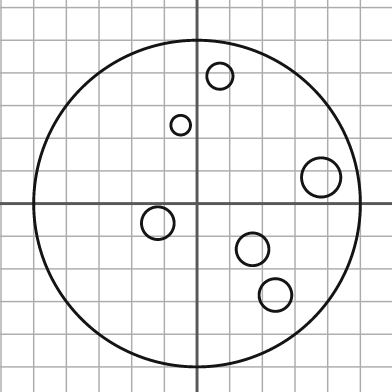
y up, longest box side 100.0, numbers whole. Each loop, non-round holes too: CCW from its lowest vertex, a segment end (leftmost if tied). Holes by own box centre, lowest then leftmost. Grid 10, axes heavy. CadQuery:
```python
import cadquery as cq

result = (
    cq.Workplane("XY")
    .moveTo(0.0, 0.0)
    .circle(50.0)
    .moveTo(24.0, -28.0)
    .circle(5.0)
    .moveTo(17.0, -14.0)
    .circle(5.0)
    .moveTo(-12.0, -6.0)
    .circle(5.0)
    .moveTo(38.0, 8.0)
    .circle(6.0)
    .moveTo(-5.0, 24.0)
    .circle(3.0)
    .moveTo(7.0, 39.0)
    .circle(4.0)
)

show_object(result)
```